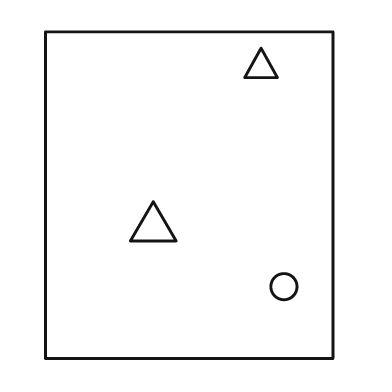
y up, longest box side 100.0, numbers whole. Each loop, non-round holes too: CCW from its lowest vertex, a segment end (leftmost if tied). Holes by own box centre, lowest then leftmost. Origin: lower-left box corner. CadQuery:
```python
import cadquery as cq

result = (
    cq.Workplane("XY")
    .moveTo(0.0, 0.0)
    .lineTo(88.0, 0.0)
    .lineTo(88.0, 100.0)
    .lineTo(0.0, 100.0)
    .close()
    .moveTo(73.0, 22.0)
    .circle(4.0)
    .moveTo(26.0, 36.0)
    .lineTo(40.0, 36.0)
    .lineTo(33.0, 48.0)
    .close()
    .moveTo(61.0, 86.0)
    .lineTo(71.0, 86.0)
    .lineTo(66.0, 95.0)
    .close()
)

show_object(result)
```